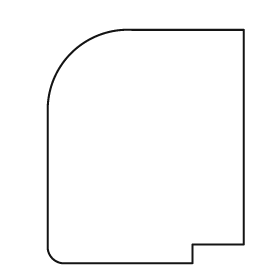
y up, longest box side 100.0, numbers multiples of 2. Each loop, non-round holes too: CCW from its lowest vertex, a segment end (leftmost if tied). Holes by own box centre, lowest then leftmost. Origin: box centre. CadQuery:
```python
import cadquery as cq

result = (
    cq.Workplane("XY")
    .moveTo(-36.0, -50.0)
    .lineTo(20.0, -50.0)
    .lineTo(20.0, -42.0)
    .lineTo(42.0, -42.0)
    .lineTo(42.0, 50.0)
    .lineTo(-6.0, 50.0)
    .threePointArc((-32.0, 40.0), (-42.0, 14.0))
    .lineTo(-42.0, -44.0)
    .threePointArc((-40.0, -48.0), (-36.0, -50.0))
    .close()
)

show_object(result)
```